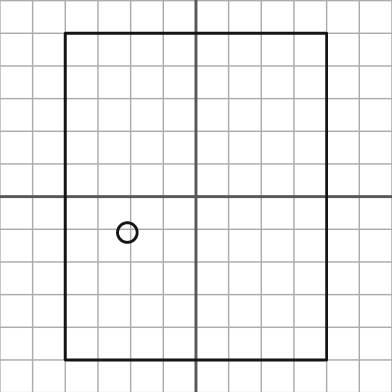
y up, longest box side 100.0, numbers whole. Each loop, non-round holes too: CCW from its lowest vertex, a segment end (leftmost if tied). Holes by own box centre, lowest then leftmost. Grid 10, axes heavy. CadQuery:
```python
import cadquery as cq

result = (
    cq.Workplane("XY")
    .moveTo(-40.0, -50.0)
    .lineTo(40.0, -50.0)
    .lineTo(40.0, 50.0)
    .lineTo(-40.0, 50.0)
    .close()
    .moveTo(-21.0, -11.0)
    .circle(3.0)
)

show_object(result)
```